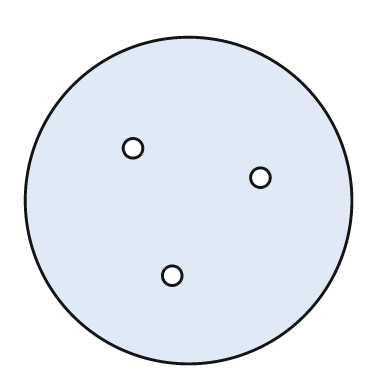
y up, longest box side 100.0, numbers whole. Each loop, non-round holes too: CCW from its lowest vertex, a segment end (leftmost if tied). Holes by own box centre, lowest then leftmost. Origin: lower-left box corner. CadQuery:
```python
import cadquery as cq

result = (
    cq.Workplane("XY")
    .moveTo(50.0, 50.0)
    .circle(50.0)
    .moveTo(45.0, 27.0)
    .circle(3.0)
    .moveTo(72.0, 57.0)
    .circle(3.0)
    .moveTo(33.0, 66.0)
    .circle(3.0)
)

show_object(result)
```